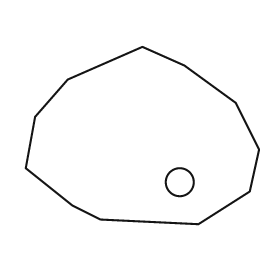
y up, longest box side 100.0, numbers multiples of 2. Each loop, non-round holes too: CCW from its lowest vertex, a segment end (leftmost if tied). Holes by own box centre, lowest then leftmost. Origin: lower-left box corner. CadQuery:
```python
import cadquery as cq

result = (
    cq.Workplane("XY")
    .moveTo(74.0, 0.0)
    .lineTo(96.0, 14.0)
    .lineTo(100.0, 32.0)
    .lineTo(90.0, 52.0)
    .lineTo(68.0, 68.0)
    .lineTo(50.0, 76.0)
    .lineTo(18.0, 62.0)
    .lineTo(4.0, 46.0)
    .lineTo(0.0, 24.0)
    .lineTo(20.0, 8.0)
    .lineTo(32.0, 2.0)
    .close()
    .moveTo(66.0, 18.0)
    .circle(6.0)
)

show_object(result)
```